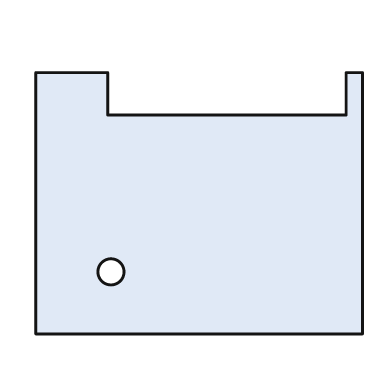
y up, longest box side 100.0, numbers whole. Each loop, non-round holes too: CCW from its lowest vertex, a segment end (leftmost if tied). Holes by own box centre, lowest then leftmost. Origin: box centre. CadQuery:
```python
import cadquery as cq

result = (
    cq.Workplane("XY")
    .moveTo(-50.0, -40.0)
    .lineTo(50.0, -40.0)
    .lineTo(50.0, 40.0)
    .lineTo(45.0, 40.0)
    .lineTo(45.0, 27.0)
    .lineTo(-28.0, 27.0)
    .lineTo(-28.0, 40.0)
    .lineTo(-50.0, 40.0)
    .close()
    .moveTo(-27.0, -21.0)
    .circle(4.0)
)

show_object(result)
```